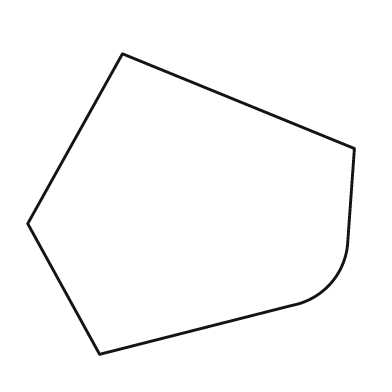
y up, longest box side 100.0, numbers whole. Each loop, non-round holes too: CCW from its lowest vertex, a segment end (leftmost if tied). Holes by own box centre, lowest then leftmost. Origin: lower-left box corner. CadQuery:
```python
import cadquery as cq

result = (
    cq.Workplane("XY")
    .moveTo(22.0, 0.0)
    .lineTo(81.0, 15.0)
    .threePointArc((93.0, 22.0), (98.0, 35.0))
    .lineTo(100.0, 63.0)
    .lineTo(29.0, 92.0)
    .lineTo(0.0, 40.0)
    .close()
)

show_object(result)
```